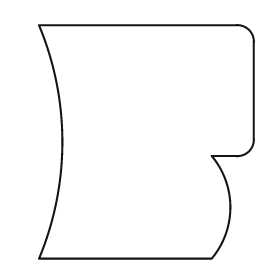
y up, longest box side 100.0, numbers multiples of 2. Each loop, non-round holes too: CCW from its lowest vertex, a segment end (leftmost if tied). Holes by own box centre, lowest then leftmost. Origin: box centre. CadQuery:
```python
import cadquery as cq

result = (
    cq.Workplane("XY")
    .moveTo(-46.0, -50.0)
    .lineTo(28.0, -50.0)
    .threePointArc((36.0, -28.0), (28.0, -6.0))
    .lineTo(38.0, -6.0)
    .threePointArc((44.0, -4.0), (46.0, 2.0))
    .lineTo(46.0, 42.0)
    .threePointArc((44.0, 48.0), (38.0, 50.0))
    .lineTo(-46.0, 50.0)
    .threePointArc((-36.0, 0.0), (-46.0, -50.0))
    .close()
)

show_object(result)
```